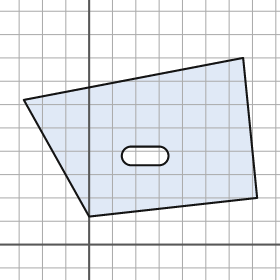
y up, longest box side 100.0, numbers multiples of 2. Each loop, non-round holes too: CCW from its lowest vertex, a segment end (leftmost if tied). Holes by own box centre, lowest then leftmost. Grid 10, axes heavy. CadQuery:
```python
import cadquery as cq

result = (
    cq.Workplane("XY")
    .moveTo(0.0, 12.0)
    .lineTo(72.0, 20.0)
    .lineTo(66.0, 80.0)
    .lineTo(-28.0, 62.0)
    .close()
    .moveTo(18.0, 34.0)
    .lineTo(30.0, 34.0)
    .threePointArc((34.0, 38.0), (30.0, 42.0))
    .lineTo(18.0, 42.0)
    .threePointArc((14.0, 38.0), (18.0, 34.0))
    .close()
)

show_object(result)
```